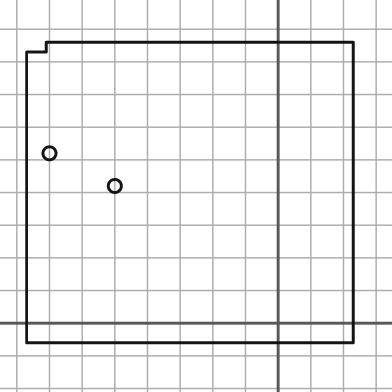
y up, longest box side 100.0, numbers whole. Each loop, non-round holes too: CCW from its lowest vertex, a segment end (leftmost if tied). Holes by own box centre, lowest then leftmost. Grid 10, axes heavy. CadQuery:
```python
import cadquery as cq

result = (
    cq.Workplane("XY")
    .moveTo(-77.0, -6.0)
    .lineTo(23.0, -6.0)
    .lineTo(23.0, 86.0)
    .lineTo(-71.0, 86.0)
    .lineTo(-71.0, 83.0)
    .lineTo(-77.0, 83.0)
    .close()
    .moveTo(-50.0, 42.0)
    .circle(2.0)
    .moveTo(-70.0, 52.0)
    .circle(2.0)
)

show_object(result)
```